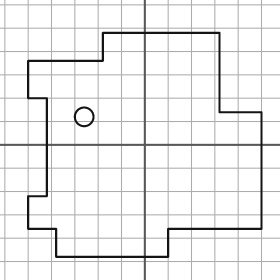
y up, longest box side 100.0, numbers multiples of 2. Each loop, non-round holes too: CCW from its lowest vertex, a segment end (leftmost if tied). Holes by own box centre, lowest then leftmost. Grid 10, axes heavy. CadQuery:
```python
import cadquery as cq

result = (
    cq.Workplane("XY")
    .moveTo(-38.0, -48.0)
    .lineTo(10.0, -48.0)
    .lineTo(10.0, -36.0)
    .lineTo(50.0, -36.0)
    .lineTo(50.0, 14.0)
    .lineTo(32.0, 14.0)
    .lineTo(32.0, 48.0)
    .lineTo(-18.0, 48.0)
    .lineTo(-18.0, 36.0)
    .lineTo(-50.0, 36.0)
    .lineTo(-50.0, 20.0)
    .lineTo(-42.0, 20.0)
    .lineTo(-42.0, -22.0)
    .lineTo(-50.0, -22.0)
    .lineTo(-50.0, -36.0)
    .lineTo(-38.0, -36.0)
    .close()
    .moveTo(-26.0, 12.0)
    .circle(4.0)
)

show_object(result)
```